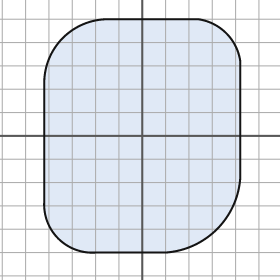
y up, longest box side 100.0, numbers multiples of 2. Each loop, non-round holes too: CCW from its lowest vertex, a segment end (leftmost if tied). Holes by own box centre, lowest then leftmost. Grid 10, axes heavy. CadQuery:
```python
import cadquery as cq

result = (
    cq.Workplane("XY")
    .moveTo(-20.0, -50.0)
    .lineTo(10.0, -50.0)
    .threePointArc((32.0, -40.0), (42.0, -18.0))
    .lineTo(42.0, 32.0)
    .threePointArc((36.0, 44.0), (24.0, 50.0))
    .lineTo(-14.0, 50.0)
    .threePointArc((-34.0, 42.0), (-42.0, 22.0))
    .lineTo(-42.0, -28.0)
    .threePointArc((-36.0, -44.0), (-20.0, -50.0))
    .close()
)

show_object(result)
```